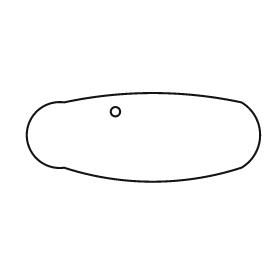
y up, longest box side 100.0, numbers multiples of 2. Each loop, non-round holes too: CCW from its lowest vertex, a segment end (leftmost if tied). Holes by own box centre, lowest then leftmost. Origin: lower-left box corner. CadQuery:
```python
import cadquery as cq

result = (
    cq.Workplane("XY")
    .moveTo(16.0, 6.0)
    .threePointArc((54.0, 0.0), (92.0, 6.0))
    .threePointArc((100.0, 20.0), (92.0, 34.0))
    .threePointArc((54.0, 38.0), (16.0, 34.0))
    .threePointArc((0.0, 20.0), (16.0, 6.0))
    .close()
    .moveTo(38.0, 30.0)
    .circle(2.0)
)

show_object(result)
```